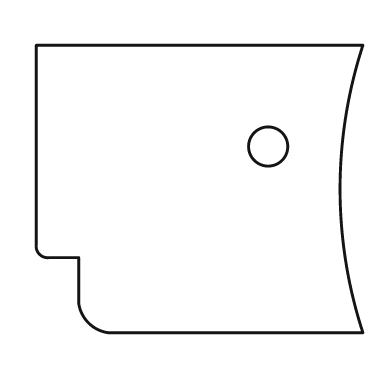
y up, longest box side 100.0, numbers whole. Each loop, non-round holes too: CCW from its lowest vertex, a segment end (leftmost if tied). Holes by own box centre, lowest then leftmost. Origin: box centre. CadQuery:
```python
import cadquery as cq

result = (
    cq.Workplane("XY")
    .moveTo(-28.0, -44.0)
    .lineTo(50.0, -44.0)
    .threePointArc((43.0, 0.0), (50.0, 44.0))
    .lineTo(-50.0, 44.0)
    .lineTo(-50.0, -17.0)
    .threePointArc((-49.0, -20.0), (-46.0, -21.0))
    .lineTo(-37.0, -21.0)
    .lineTo(-37.0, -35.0)
    .threePointArc((-34.0, -41.0), (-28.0, -44.0))
    .close()
    .moveTo(21.0, 13.0)
    .circle(6.0)
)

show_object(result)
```